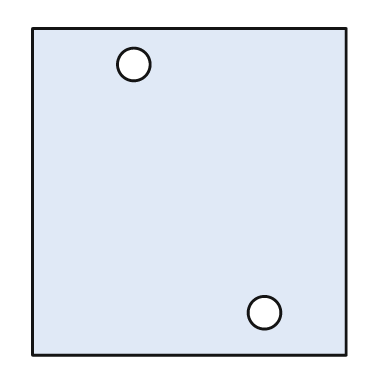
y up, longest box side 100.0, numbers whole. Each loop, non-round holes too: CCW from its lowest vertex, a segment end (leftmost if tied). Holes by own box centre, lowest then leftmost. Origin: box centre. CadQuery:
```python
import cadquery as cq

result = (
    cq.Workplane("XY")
    .moveTo(-48.0, -50.0)
    .lineTo(48.0, -50.0)
    .lineTo(48.0, 50.0)
    .lineTo(-48.0, 50.0)
    .close()
    .moveTo(23.0, -37.0)
    .circle(5.0)
    .moveTo(-17.0, 39.0)
    .circle(5.0)
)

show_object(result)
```